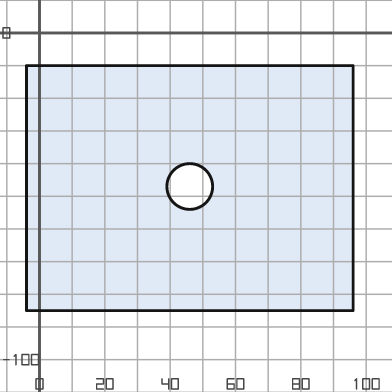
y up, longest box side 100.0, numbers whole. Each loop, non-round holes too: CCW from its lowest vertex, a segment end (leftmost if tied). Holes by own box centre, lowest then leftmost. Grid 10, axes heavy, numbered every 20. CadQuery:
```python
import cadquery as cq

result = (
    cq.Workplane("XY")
    .moveTo(-4.0, -85.0)
    .lineTo(96.0, -85.0)
    .lineTo(96.0, -10.0)
    .lineTo(-4.0, -10.0)
    .close()
    .moveTo(46.0, -47.0)
    .circle(7.0)
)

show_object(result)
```